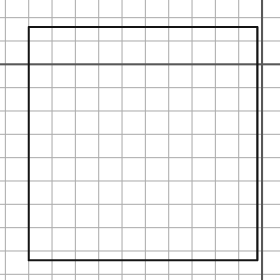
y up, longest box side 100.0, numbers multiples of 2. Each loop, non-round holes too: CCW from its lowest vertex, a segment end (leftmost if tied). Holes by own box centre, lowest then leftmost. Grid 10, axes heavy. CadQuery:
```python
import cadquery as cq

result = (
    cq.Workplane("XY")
    .moveTo(-100.0, -84.0)
    .lineTo(-2.0, -84.0)
    .lineTo(-2.0, 16.0)
    .lineTo(-100.0, 16.0)
    .close()
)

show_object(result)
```